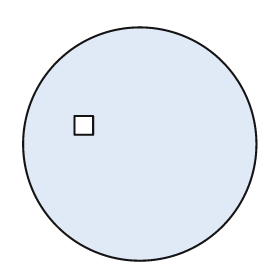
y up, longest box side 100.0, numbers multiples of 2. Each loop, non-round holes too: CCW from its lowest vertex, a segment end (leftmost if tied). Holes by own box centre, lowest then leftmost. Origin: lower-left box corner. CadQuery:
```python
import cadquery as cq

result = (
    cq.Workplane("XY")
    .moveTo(50.0, 50.0)
    .circle(50.0)
    .moveTo(22.0, 54.0)
    .lineTo(30.0, 54.0)
    .lineTo(30.0, 62.0)
    .lineTo(22.0, 62.0)
    .close()
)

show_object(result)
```